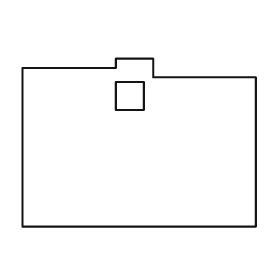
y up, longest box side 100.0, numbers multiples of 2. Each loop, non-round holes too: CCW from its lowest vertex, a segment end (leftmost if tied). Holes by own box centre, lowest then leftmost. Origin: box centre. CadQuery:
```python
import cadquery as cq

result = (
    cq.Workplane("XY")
    .moveTo(-50.0, -36.0)
    .lineTo(50.0, -36.0)
    .lineTo(50.0, 28.0)
    .lineTo(6.0, 28.0)
    .lineTo(6.0, 36.0)
    .lineTo(-10.0, 36.0)
    .lineTo(-10.0, 32.0)
    .lineTo(-50.0, 32.0)
    .close()
    .moveTo(-10.0, 14.0)
    .lineTo(2.0, 14.0)
    .lineTo(2.0, 26.0)
    .lineTo(-10.0, 26.0)
    .close()
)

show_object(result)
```